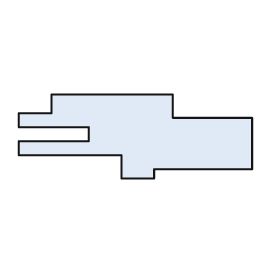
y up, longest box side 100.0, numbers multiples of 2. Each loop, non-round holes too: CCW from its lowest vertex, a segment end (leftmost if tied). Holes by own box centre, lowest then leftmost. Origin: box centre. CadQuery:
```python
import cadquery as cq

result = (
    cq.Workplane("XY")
    .moveTo(-6.0, -18.0)
    .lineTo(8.0, -18.0)
    .lineTo(8.0, -14.0)
    .lineTo(50.0, -14.0)
    .lineTo(50.0, 8.0)
    .lineTo(16.0, 8.0)
    .lineTo(16.0, 18.0)
    .lineTo(-36.0, 18.0)
    .lineTo(-36.0, 10.0)
    .lineTo(-50.0, 10.0)
    .lineTo(-50.0, 4.0)
    .lineTo(-20.0, 4.0)
    .lineTo(-20.0, -2.0)
    .lineTo(-50.0, -2.0)
    .lineTo(-50.0, -8.0)
    .lineTo(-6.0, -8.0)
    .close()
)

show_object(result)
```